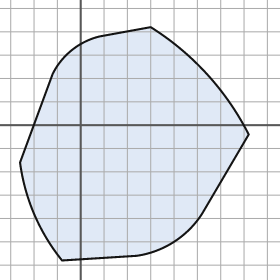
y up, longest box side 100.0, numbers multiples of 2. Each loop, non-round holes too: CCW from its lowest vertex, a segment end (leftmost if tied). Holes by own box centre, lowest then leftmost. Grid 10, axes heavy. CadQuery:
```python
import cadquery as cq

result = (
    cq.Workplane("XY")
    .moveTo(-8.0, -58.0)
    .lineTo(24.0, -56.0)
    .threePointArc((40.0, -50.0), (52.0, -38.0))
    .lineTo(72.0, -4.0)
    .threePointArc((54.0, 22.0), (30.0, 42.0))
    .lineTo(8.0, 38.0)
    .threePointArc((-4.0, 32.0), (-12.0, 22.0))
    .lineTo(-26.0, -16.0)
    .threePointArc((-20.0, -38.0), (-8.0, -58.0))
    .close()
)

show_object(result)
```